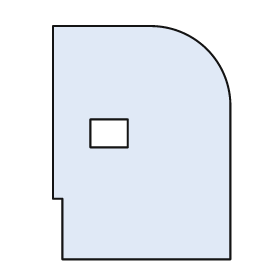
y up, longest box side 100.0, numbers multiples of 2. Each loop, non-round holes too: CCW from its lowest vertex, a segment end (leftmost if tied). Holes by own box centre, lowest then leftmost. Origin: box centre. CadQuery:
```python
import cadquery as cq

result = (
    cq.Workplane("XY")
    .moveTo(-34.0, -50.0)
    .lineTo(38.0, -50.0)
    .lineTo(38.0, 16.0)
    .threePointArc((28.0, 40.0), (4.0, 50.0))
    .lineTo(-38.0, 50.0)
    .lineTo(-38.0, -24.0)
    .lineTo(-34.0, -24.0)
    .close()
    .moveTo(-22.0, -2.0)
    .lineTo(-6.0, -2.0)
    .lineTo(-6.0, 10.0)
    .lineTo(-22.0, 10.0)
    .close()
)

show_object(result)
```